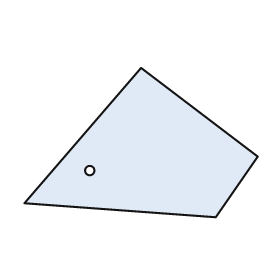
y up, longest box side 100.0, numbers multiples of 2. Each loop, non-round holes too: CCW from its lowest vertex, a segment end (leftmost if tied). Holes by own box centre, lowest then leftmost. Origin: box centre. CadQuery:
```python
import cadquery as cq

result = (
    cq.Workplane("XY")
    .moveTo(32.0, -32.0)
    .lineTo(50.0, -6.0)
    .lineTo(0.0, 32.0)
    .lineTo(-50.0, -26.0)
    .close()
    .moveTo(-22.0, -12.0)
    .circle(2.0)
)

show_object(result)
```